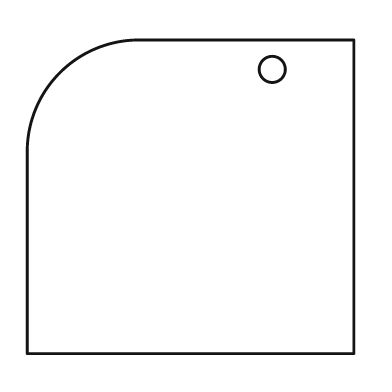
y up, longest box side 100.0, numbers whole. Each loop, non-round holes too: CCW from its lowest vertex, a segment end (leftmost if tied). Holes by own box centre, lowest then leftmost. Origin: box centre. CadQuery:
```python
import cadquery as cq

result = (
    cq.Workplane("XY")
    .moveTo(-50.0, -48.0)
    .lineTo(50.0, -48.0)
    .lineTo(50.0, 48.0)
    .lineTo(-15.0, 48.0)
    .threePointArc((-40.0, 38.0), (-50.0, 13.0))
    .close()
    .moveTo(25.0, 39.0)
    .circle(4.0)
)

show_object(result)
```